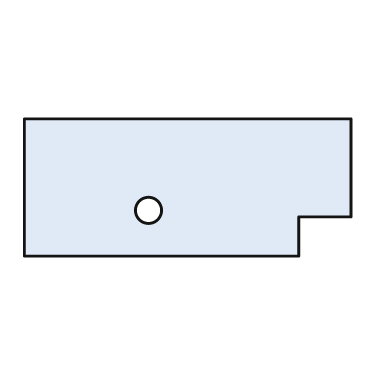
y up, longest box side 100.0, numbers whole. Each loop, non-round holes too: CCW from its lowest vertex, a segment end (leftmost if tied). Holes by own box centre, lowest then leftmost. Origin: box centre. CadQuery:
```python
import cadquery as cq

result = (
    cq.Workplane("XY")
    .moveTo(-50.0, -21.0)
    .lineTo(34.0, -21.0)
    .lineTo(34.0, -9.0)
    .lineTo(50.0, -9.0)
    .lineTo(50.0, 21.0)
    .lineTo(-50.0, 21.0)
    .close()
    .moveTo(-12.0, -7.0)
    .circle(4.0)
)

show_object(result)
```